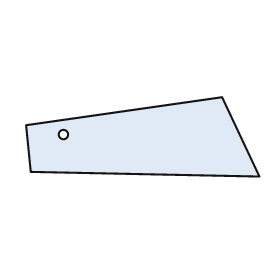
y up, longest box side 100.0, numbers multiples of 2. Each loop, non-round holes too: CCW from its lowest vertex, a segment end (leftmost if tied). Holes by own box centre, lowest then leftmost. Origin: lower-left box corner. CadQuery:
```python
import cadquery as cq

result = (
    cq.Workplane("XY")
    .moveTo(100.0, 0.0)
    .lineTo(84.0, 34.0)
    .lineTo(0.0, 22.0)
    .lineTo(2.0, 2.0)
    .close()
    .moveTo(16.0, 18.0)
    .circle(2.0)
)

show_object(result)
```